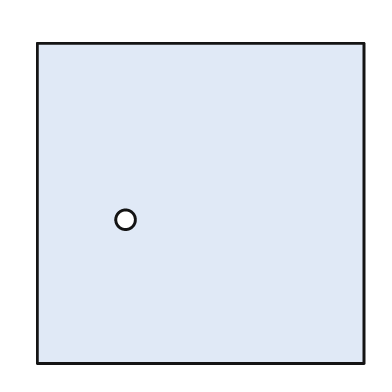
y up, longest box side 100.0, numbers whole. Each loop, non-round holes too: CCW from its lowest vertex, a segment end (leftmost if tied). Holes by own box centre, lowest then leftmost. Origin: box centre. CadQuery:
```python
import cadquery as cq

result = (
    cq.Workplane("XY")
    .moveTo(-50.0, -49.0)
    .lineTo(50.0, -49.0)
    .lineTo(50.0, 49.0)
    .lineTo(-50.0, 49.0)
    .close()
    .moveTo(-23.0, -5.0)
    .circle(3.0)
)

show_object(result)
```